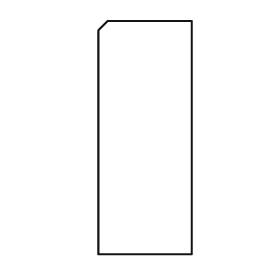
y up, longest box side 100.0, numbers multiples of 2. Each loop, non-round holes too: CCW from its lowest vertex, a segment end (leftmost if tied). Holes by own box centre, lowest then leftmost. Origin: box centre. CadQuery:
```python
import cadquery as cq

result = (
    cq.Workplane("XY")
    .moveTo(-20.0, -50.0)
    .lineTo(20.0, -50.0)
    .lineTo(20.0, 50.0)
    .lineTo(-16.0, 50.0)
    .lineTo(-20.0, 46.0)
    .close()
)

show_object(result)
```